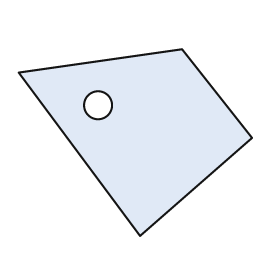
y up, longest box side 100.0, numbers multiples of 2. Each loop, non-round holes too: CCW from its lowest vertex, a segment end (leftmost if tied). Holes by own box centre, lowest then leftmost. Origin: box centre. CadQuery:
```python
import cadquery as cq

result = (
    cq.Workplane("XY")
    .moveTo(2.0, -40.0)
    .lineTo(50.0, 2.0)
    .lineTo(20.0, 40.0)
    .lineTo(-50.0, 30.0)
    .close()
    .moveTo(-16.0, 16.0)
    .circle(6.0)
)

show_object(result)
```